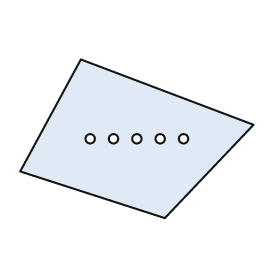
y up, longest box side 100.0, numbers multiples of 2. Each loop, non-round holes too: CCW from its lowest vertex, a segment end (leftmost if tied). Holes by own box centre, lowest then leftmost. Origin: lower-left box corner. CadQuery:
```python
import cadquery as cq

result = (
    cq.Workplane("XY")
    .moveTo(62.0, 0.0)
    .lineTo(100.0, 40.0)
    .lineTo(26.0, 68.0)
    .lineTo(0.0, 20.0)
    .close()
    .moveTo(30.0, 34.0)
    .circle(2.0)
    .moveTo(40.0, 34.0)
    .circle(2.0)
    .moveTo(50.0, 34.0)
    .circle(2.0)
    .moveTo(60.0, 34.0)
    .circle(2.0)
    .moveTo(70.0, 34.0)
    .circle(2.0)
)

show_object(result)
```